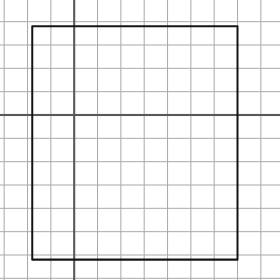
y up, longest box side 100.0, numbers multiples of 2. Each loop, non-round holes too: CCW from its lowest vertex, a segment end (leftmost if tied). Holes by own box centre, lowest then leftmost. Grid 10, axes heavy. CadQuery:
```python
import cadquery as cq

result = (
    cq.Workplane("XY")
    .moveTo(-18.0, -62.0)
    .lineTo(70.0, -62.0)
    .lineTo(70.0, 38.0)
    .lineTo(-18.0, 38.0)
    .close()
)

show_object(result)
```